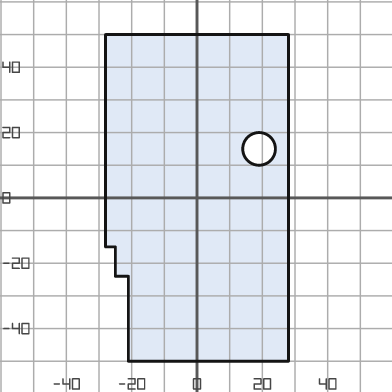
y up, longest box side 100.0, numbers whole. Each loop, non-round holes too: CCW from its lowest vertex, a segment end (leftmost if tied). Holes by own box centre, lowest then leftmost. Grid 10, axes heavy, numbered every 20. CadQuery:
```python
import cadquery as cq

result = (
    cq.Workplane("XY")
    .moveTo(-21.0, -50.0)
    .lineTo(28.0, -50.0)
    .lineTo(28.0, 50.0)
    .lineTo(-28.0, 50.0)
    .lineTo(-28.0, -15.0)
    .lineTo(-25.0, -15.0)
    .lineTo(-25.0, -24.0)
    .lineTo(-21.0, -24.0)
    .close()
    .moveTo(19.0, 15.0)
    .circle(5.0)
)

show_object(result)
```